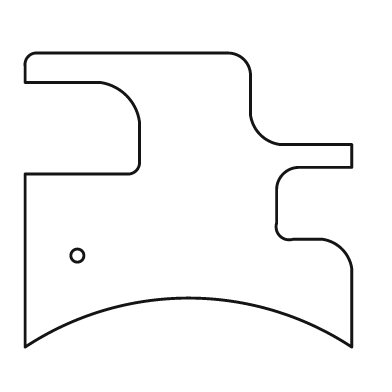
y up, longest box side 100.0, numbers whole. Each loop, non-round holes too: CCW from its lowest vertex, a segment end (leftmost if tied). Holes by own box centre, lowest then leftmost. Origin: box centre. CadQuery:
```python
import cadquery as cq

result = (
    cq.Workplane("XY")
    .moveTo(-50.0, -45.0)
    .threePointArc((0.0, -30.0), (50.0, -45.0))
    .lineTo(50.0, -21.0)
    .threePointArc((47.0, -15.0), (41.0, -12.0))
    .lineTo(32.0, -12.0)
    .threePointArc((28.0, -11.0), (27.0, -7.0))
    .lineTo(27.0, 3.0)
    .threePointArc((29.0, 8.0), (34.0, 10.0))
    .lineTo(50.0, 10.0)
    .lineTo(50.0, 17.0)
    .lineTo(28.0, 17.0)
    .threePointArc((22.0, 20.0), (19.0, 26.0))
    .lineTo(19.0, 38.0)
    .threePointArc((17.0, 43.0), (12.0, 45.0))
    .lineTo(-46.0, 45.0)
    .threePointArc((-49.0, 44.0), (-50.0, 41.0))
    .lineTo(-50.0, 36.0)
    .lineTo(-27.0, 36.0)
    .threePointArc((-19.0, 32.0), (-15.0, 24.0))
    .lineTo(-15.0, 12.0)
    .threePointArc((-16.0, 9.0), (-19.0, 8.0))
    .lineTo(-50.0, 8.0)
    .close()
    .moveTo(-34.0, -17.0)
    .circle(2.0)
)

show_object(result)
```